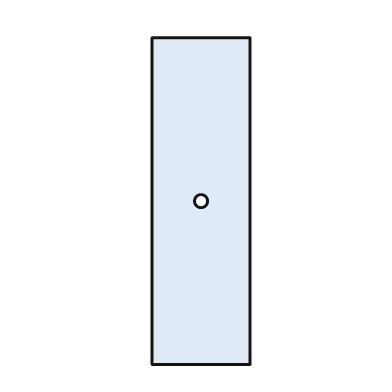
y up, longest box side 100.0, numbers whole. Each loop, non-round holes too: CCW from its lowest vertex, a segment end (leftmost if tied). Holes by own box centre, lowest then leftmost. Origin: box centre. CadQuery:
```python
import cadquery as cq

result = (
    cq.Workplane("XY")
    .moveTo(-15.0, -50.0)
    .lineTo(15.0, -50.0)
    .lineTo(15.0, 50.0)
    .lineTo(-15.0, 50.0)
    .close()
    .moveTo(0.0, 0.0)
    .circle(2.0)
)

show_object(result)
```